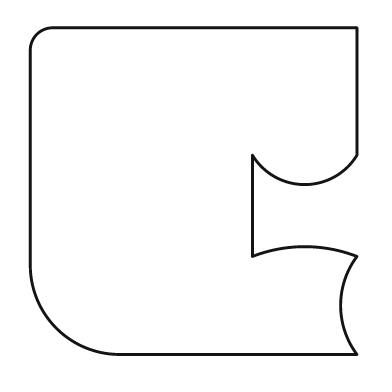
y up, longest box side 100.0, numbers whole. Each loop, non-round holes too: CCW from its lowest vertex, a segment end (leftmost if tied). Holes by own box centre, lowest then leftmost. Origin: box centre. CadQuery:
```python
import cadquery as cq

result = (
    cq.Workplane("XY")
    .moveTo(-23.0, -50.0)
    .lineTo(50.0, -50.0)
    .threePointArc((45.0, -35.0), (50.0, -20.0))
    .threePointArc((34.0, -17.0), (18.0, -20.0))
    .lineTo(18.0, 11.0)
    .threePointArc((34.0, 2.0), (50.0, 11.0))
    .lineTo(50.0, 50.0)
    .lineTo(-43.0, 50.0)
    .threePointArc((-48.0, 48.0), (-50.0, 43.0))
    .lineTo(-50.0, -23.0)
    .threePointArc((-42.0, -42.0), (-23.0, -50.0))
    .close()
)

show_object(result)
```